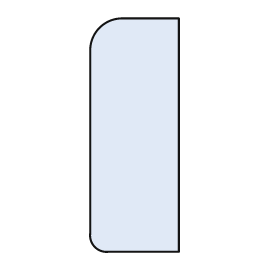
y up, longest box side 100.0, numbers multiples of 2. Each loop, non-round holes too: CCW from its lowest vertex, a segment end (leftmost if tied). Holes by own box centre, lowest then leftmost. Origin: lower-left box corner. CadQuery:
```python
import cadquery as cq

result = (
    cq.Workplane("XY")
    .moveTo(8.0, 0.0)
    .lineTo(38.0, 0.0)
    .lineTo(38.0, 100.0)
    .lineTo(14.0, 100.0)
    .threePointArc((4.0, 96.0), (0.0, 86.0))
    .lineTo(0.0, 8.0)
    .threePointArc((2.0, 2.0), (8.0, 0.0))
    .close()
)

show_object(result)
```